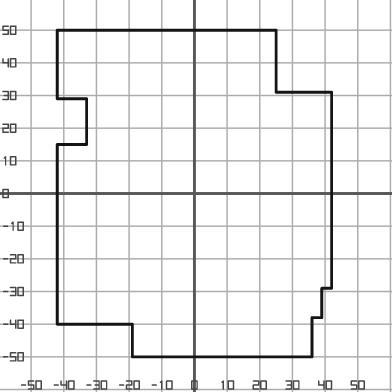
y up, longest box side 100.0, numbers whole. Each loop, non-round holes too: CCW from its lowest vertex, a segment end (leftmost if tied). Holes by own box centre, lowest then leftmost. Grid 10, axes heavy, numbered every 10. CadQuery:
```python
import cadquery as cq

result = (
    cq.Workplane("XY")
    .moveTo(-19.0, -50.0)
    .lineTo(36.0, -50.0)
    .lineTo(36.0, -38.0)
    .lineTo(39.0, -38.0)
    .lineTo(39.0, -29.0)
    .lineTo(42.0, -29.0)
    .lineTo(42.0, 31.0)
    .lineTo(25.0, 31.0)
    .lineTo(25.0, 50.0)
    .lineTo(-42.0, 50.0)
    .lineTo(-42.0, 29.0)
    .lineTo(-33.0, 29.0)
    .lineTo(-33.0, 15.0)
    .lineTo(-42.0, 15.0)
    .lineTo(-42.0, -40.0)
    .lineTo(-19.0, -40.0)
    .close()
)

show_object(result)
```